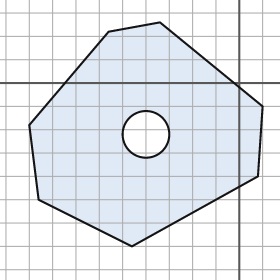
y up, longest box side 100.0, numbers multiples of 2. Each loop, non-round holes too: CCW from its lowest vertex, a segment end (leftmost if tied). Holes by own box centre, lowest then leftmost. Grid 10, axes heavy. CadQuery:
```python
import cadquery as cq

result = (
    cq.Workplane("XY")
    .moveTo(-46.0, -70.0)
    .lineTo(8.0, -40.0)
    .lineTo(10.0, -10.0)
    .lineTo(-34.0, 26.0)
    .lineTo(-56.0, 22.0)
    .lineTo(-90.0, -18.0)
    .lineTo(-86.0, -50.0)
    .close()
    .moveTo(-40.0, -22.0)
    .circle(10.0)
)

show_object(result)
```